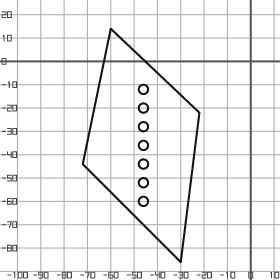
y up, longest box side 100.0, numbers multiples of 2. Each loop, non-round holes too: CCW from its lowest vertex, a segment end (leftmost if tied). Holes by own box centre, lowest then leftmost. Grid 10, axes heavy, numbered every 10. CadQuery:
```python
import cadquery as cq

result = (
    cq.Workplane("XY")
    .moveTo(-30.0, -86.0)
    .lineTo(-22.0, -22.0)
    .lineTo(-60.0, 14.0)
    .lineTo(-72.0, -44.0)
    .close()
    .moveTo(-46.0, -60.0)
    .circle(2.0)
    .moveTo(-46.0, -52.0)
    .circle(2.0)
    .moveTo(-46.0, -44.0)
    .circle(2.0)
    .moveTo(-46.0, -36.0)
    .circle(2.0)
    .moveTo(-46.0, -28.0)
    .circle(2.0)
    .moveTo(-46.0, -20.0)
    .circle(2.0)
    .moveTo(-46.0, -12.0)
    .circle(2.0)
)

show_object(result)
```